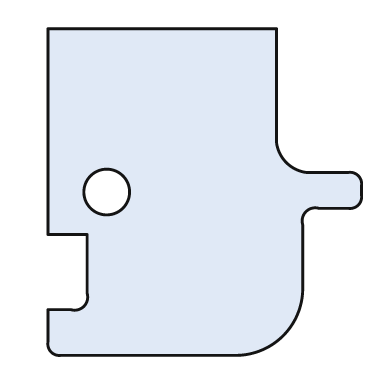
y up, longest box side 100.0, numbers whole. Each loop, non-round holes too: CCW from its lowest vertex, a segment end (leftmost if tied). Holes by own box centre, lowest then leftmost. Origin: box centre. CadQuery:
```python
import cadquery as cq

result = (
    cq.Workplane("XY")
    .moveTo(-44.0, -50.0)
    .lineTo(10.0, -50.0)
    .threePointArc((24.0, -44.0), (30.0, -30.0))
    .lineTo(30.0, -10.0)
    .threePointArc((31.0, -6.0), (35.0, -5.0))
    .lineTo(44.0, -5.0)
    .threePointArc((47.0, -4.0), (48.0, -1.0))
    .lineTo(48.0, 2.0)
    .threePointArc((47.0, 5.0), (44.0, 6.0))
    .lineTo(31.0, 6.0)
    .threePointArc((25.0, 9.0), (22.0, 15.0))
    .lineTo(22.0, 50.0)
    .lineTo(-48.0, 50.0)
    .lineTo(-48.0, -13.0)
    .lineTo(-36.0, -13.0)
    .lineTo(-36.0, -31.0)
    .threePointArc((-37.0, -35.0), (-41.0, -36.0))
    .lineTo(-48.0, -36.0)
    .lineTo(-48.0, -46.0)
    .threePointArc((-47.0, -49.0), (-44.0, -50.0))
    .close()
    .moveTo(-30.0, 0.0)
    .circle(7.0)
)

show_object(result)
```